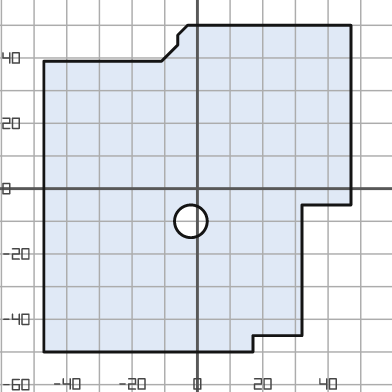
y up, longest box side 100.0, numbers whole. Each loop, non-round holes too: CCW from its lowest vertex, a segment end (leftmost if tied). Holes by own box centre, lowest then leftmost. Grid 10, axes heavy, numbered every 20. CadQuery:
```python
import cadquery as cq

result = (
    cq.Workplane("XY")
    .moveTo(-47.0, -50.0)
    .lineTo(17.0, -50.0)
    .lineTo(17.0, -45.0)
    .lineTo(32.0, -45.0)
    .lineTo(32.0, -5.0)
    .lineTo(47.0, -5.0)
    .lineTo(47.0, 50.0)
    .lineTo(-3.0, 50.0)
    .lineTo(-6.0, 47.0)
    .lineTo(-6.0, 44.0)
    .lineTo(-11.0, 39.0)
    .lineTo(-47.0, 39.0)
    .close()
    .moveTo(-2.0, -10.0)
    .circle(5.0)
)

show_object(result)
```